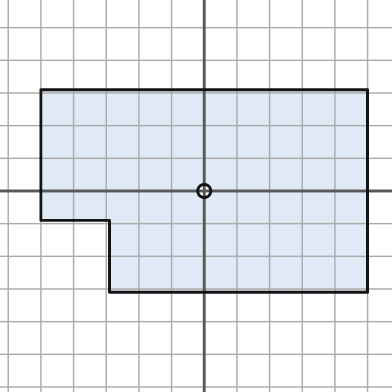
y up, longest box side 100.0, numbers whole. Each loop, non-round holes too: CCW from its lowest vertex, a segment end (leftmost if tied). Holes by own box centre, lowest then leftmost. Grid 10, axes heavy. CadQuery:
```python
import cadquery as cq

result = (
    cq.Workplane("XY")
    .moveTo(-29.0, -31.0)
    .lineTo(50.0, -31.0)
    .lineTo(50.0, 31.0)
    .lineTo(-50.0, 31.0)
    .lineTo(-50.0, -9.0)
    .lineTo(-29.0, -9.0)
    .close()
    .moveTo(0.0, 0.0)
    .circle(2.0)
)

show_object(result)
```